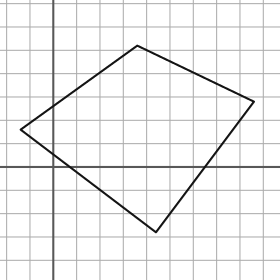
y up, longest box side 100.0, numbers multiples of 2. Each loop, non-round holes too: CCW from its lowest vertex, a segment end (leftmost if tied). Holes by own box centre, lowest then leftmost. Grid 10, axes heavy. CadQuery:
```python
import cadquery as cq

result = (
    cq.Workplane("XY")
    .moveTo(44.0, -28.0)
    .lineTo(86.0, 28.0)
    .lineTo(36.0, 52.0)
    .lineTo(-14.0, 16.0)
    .close()
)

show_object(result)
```